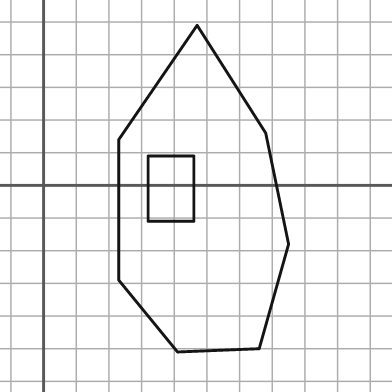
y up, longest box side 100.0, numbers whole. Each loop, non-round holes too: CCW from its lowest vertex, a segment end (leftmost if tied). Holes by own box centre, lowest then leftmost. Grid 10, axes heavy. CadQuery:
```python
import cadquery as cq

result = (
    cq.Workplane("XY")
    .moveTo(41.0, -51.0)
    .lineTo(66.0, -50.0)
    .lineTo(75.0, -18.0)
    .lineTo(68.0, 16.0)
    .lineTo(47.0, 49.0)
    .lineTo(23.0, 14.0)
    .lineTo(23.0, -29.0)
    .close()
    .moveTo(32.0, -11.0)
    .lineTo(46.0, -11.0)
    .lineTo(46.0, 9.0)
    .lineTo(32.0, 9.0)
    .close()
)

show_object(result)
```